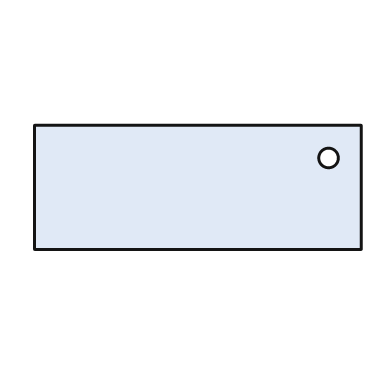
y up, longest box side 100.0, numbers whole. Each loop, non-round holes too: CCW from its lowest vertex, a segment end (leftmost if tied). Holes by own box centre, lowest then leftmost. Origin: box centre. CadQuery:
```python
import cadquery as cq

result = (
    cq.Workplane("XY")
    .moveTo(-50.0, -19.0)
    .lineTo(50.0, -19.0)
    .lineTo(50.0, 19.0)
    .lineTo(-50.0, 19.0)
    .close()
    .moveTo(40.0, 9.0)
    .circle(3.0)
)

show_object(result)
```